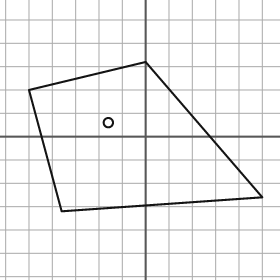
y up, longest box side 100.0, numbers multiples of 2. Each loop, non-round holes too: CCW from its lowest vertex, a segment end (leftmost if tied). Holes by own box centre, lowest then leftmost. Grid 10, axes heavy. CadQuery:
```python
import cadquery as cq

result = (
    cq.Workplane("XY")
    .moveTo(-36.0, -32.0)
    .lineTo(50.0, -26.0)
    .lineTo(0.0, 32.0)
    .lineTo(-50.0, 20.0)
    .close()
    .moveTo(-16.0, 6.0)
    .circle(2.0)
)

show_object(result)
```